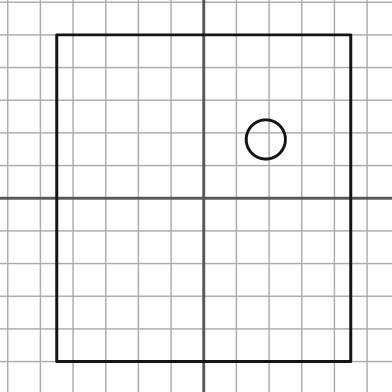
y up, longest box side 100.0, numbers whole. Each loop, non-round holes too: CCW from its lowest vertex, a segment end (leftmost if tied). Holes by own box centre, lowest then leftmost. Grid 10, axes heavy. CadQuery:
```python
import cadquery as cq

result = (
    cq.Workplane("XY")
    .moveTo(-45.0, -50.0)
    .lineTo(45.0, -50.0)
    .lineTo(45.0, 50.0)
    .lineTo(-45.0, 50.0)
    .close()
    .moveTo(19.0, 18.0)
    .circle(6.0)
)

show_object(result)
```